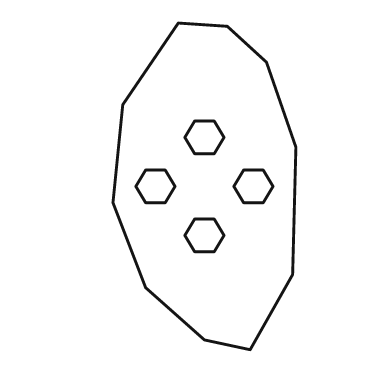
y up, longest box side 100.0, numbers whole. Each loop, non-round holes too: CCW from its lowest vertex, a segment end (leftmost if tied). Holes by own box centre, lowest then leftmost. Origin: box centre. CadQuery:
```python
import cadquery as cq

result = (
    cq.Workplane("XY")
    .moveTo(14.0, -50.0)
    .lineTo(27.0, -27.0)
    .lineTo(28.0, 12.0)
    .lineTo(19.0, 38.0)
    .lineTo(7.0, 49.0)
    .lineTo(-8.0, 50.0)
    .lineTo(-25.0, 25.0)
    .lineTo(-28.0, -5.0)
    .lineTo(-18.0, -31.0)
    .lineTo(0.0, -47.0)
    .close()
    .moveTo(-3.0, -20.0)
    .lineTo(3.0, -20.0)
    .lineTo(6.0, -15.0)
    .lineTo(3.0, -10.0)
    .lineTo(-3.0, -10.0)
    .lineTo(-6.0, -15.0)
    .close()
    .moveTo(-18.0, -5.0)
    .lineTo(-12.0, -5.0)
    .lineTo(-9.0, 0.0)
    .lineTo(-12.0, 5.0)
    .lineTo(-18.0, 5.0)
    .lineTo(-21.0, 0.0)
    .close()
    .moveTo(12.0, -5.0)
    .lineTo(18.0, -5.0)
    .lineTo(21.0, 0.0)
    .lineTo(18.0, 5.0)
    .lineTo(12.0, 5.0)
    .lineTo(9.0, 0.0)
    .close()
    .moveTo(-3.0, 10.0)
    .lineTo(3.0, 10.0)
    .lineTo(6.0, 15.0)
    .lineTo(3.0, 20.0)
    .lineTo(-3.0, 20.0)
    .lineTo(-6.0, 15.0)
    .close()
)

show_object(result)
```